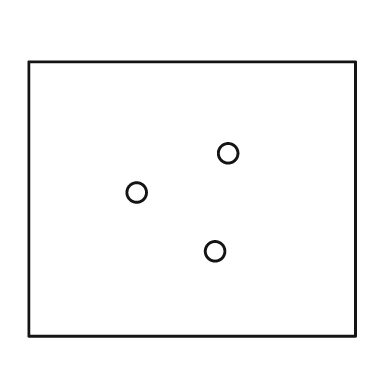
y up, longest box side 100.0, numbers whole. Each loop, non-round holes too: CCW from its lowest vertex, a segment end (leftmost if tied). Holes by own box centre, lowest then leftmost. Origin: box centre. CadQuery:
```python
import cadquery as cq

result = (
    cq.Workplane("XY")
    .moveTo(-50.0, -42.0)
    .lineTo(50.0, -42.0)
    .lineTo(50.0, 42.0)
    .lineTo(-50.0, 42.0)
    .close()
    .moveTo(7.0, -16.0)
    .circle(3.0)
    .moveTo(-17.0, 2.0)
    .circle(3.0)
    .moveTo(11.0, 14.0)
    .circle(3.0)
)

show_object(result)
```